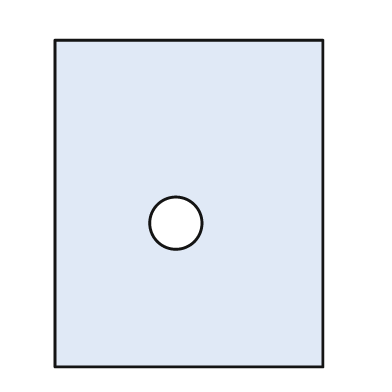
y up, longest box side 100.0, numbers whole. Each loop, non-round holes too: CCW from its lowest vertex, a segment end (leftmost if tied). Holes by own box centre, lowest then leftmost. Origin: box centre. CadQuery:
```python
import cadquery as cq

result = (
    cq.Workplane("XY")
    .moveTo(-41.0, -50.0)
    .lineTo(41.0, -50.0)
    .lineTo(41.0, 50.0)
    .lineTo(-41.0, 50.0)
    .close()
    .moveTo(-4.0, -6.0)
    .circle(8.0)
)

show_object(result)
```